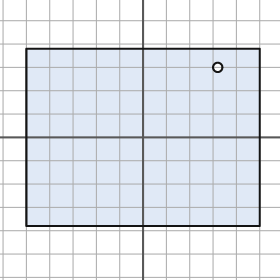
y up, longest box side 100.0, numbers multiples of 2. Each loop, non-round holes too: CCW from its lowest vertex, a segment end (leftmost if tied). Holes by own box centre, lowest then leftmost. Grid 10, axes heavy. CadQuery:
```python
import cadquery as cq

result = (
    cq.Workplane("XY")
    .moveTo(-50.0, -38.0)
    .lineTo(50.0, -38.0)
    .lineTo(50.0, 38.0)
    .lineTo(-50.0, 38.0)
    .close()
    .moveTo(32.0, 30.0)
    .circle(2.0)
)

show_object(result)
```